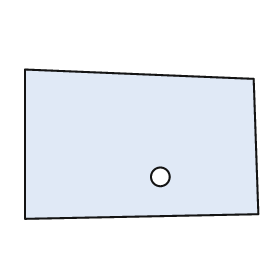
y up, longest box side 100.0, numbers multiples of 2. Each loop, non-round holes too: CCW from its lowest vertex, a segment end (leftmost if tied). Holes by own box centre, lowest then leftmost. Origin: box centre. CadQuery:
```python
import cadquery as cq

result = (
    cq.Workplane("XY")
    .moveTo(-50.0, -32.0)
    .lineTo(50.0, -30.0)
    .lineTo(48.0, 28.0)
    .lineTo(-50.0, 32.0)
    .close()
    .moveTo(8.0, -14.0)
    .circle(4.0)
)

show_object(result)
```